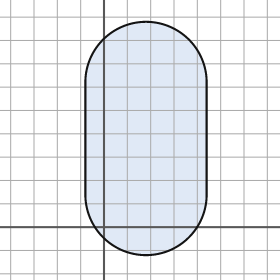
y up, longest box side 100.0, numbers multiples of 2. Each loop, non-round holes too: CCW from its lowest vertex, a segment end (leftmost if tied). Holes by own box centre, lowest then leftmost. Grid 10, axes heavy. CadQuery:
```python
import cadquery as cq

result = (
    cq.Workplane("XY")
    .moveTo(-8.0, 14.0)
    .threePointArc((18.0, -12.0), (44.0, 14.0))
    .lineTo(44.0, 62.0)
    .threePointArc((18.0, 88.0), (-8.0, 62.0))
    .close()
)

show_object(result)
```